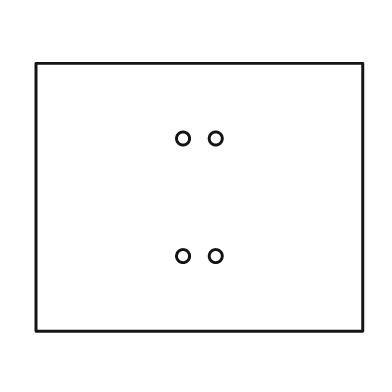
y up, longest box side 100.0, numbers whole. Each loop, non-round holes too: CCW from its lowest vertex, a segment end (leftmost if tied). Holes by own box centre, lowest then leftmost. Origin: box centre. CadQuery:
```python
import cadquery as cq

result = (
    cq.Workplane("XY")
    .moveTo(-50.0, -41.0)
    .lineTo(50.0, -41.0)
    .lineTo(50.0, 41.0)
    .lineTo(-50.0, 41.0)
    .close()
    .moveTo(-5.0, -18.0)
    .circle(2.0)
    .moveTo(5.0, -18.0)
    .circle(2.0)
    .moveTo(-5.0, 18.0)
    .circle(2.0)
    .moveTo(5.0, 18.0)
    .circle(2.0)
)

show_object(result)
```